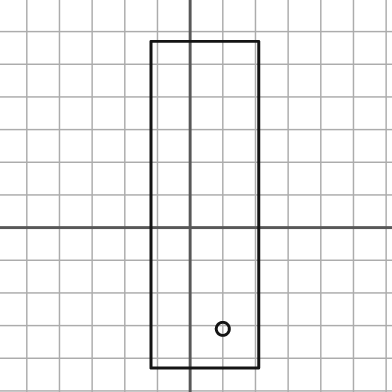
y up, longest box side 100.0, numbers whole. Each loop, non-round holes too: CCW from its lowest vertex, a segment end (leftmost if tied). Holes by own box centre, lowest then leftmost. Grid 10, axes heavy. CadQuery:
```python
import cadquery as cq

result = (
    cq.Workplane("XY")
    .moveTo(-12.0, -43.0)
    .lineTo(21.0, -43.0)
    .lineTo(21.0, 57.0)
    .lineTo(-12.0, 57.0)
    .close()
    .moveTo(10.0, -31.0)
    .circle(2.0)
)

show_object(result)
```